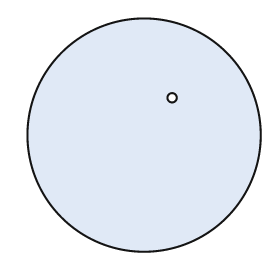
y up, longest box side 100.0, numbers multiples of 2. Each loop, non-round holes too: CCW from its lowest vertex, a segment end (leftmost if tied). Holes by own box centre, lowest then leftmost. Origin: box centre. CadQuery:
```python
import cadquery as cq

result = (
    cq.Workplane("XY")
    .moveTo(0.0, 0.0)
    .circle(50.0)
    .moveTo(12.0, 16.0)
    .circle(2.0)
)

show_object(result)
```